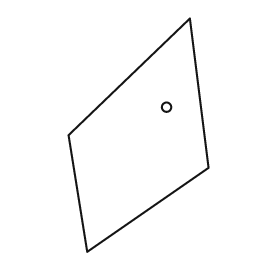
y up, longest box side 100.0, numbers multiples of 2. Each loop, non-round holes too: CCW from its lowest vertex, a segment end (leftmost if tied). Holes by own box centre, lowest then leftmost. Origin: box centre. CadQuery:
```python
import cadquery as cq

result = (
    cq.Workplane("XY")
    .moveTo(-22.0, -50.0)
    .lineTo(30.0, -14.0)
    .lineTo(22.0, 50.0)
    .lineTo(-30.0, 0.0)
    .close()
    .moveTo(12.0, 12.0)
    .circle(2.0)
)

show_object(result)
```